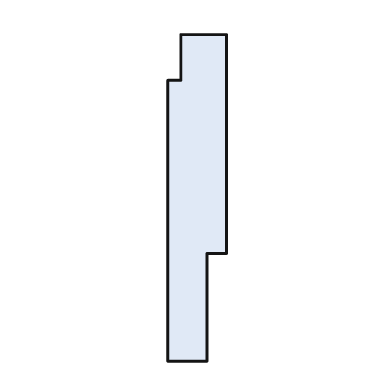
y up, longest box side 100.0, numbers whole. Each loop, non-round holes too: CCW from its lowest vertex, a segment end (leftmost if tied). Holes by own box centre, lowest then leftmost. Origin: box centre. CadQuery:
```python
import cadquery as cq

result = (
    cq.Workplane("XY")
    .moveTo(-9.0, -50.0)
    .lineTo(3.0, -50.0)
    .lineTo(3.0, -17.0)
    .lineTo(9.0, -17.0)
    .lineTo(9.0, 50.0)
    .lineTo(-5.0, 50.0)
    .lineTo(-5.0, 36.0)
    .lineTo(-9.0, 36.0)
    .close()
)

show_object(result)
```